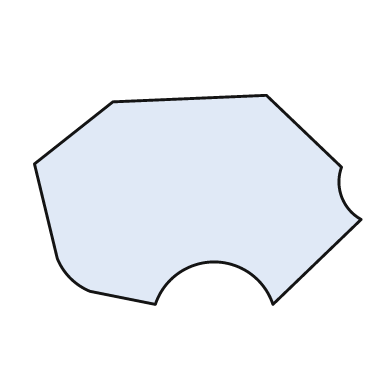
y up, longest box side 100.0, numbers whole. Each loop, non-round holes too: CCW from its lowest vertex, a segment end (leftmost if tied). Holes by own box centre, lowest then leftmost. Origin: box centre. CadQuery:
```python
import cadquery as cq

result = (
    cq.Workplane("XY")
    .moveTo(-13.0, -32.0)
    .threePointArc((5.0, -19.0), (23.0, -32.0))
    .lineTo(50.0, -6.0)
    .threePointArc((44.0, 1.0), (44.0, 10.0))
    .lineTo(21.0, 32.0)
    .lineTo(-26.0, 30.0)
    .lineTo(-50.0, 11.0)
    .lineTo(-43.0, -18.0)
    .threePointArc((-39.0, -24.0), (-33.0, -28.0))
    .close()
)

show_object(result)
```